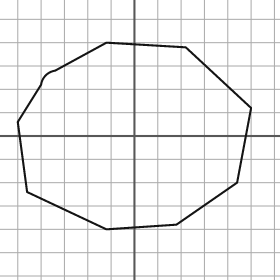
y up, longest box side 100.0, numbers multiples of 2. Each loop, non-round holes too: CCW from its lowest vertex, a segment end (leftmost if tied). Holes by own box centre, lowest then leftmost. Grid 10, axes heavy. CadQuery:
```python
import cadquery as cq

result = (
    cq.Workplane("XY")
    .moveTo(-12.0, -40.0)
    .lineTo(18.0, -38.0)
    .lineTo(44.0, -20.0)
    .lineTo(50.0, 12.0)
    .lineTo(22.0, 38.0)
    .lineTo(-12.0, 40.0)
    .lineTo(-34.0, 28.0)
    .threePointArc((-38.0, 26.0), (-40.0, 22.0))
    .lineTo(-50.0, 6.0)
    .lineTo(-46.0, -24.0)
    .close()
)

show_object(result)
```